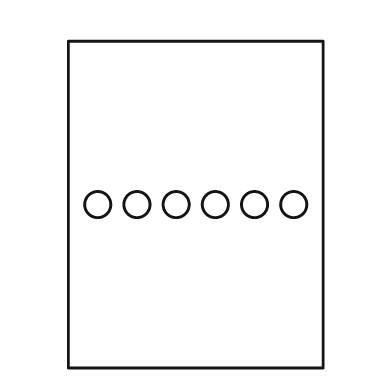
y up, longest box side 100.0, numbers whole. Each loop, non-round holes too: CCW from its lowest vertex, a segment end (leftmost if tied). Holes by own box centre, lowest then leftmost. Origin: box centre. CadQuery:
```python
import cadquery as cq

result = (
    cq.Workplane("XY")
    .moveTo(-39.0, -50.0)
    .lineTo(39.0, -50.0)
    .lineTo(39.0, 50.0)
    .lineTo(-39.0, 50.0)
    .close()
    .moveTo(-30.0, 0.0)
    .circle(4.0)
    .moveTo(-18.0, 0.0)
    .circle(4.0)
    .moveTo(-6.0, 0.0)
    .circle(4.0)
    .moveTo(6.0, 0.0)
    .circle(4.0)
    .moveTo(18.0, 0.0)
    .circle(4.0)
    .moveTo(30.0, 0.0)
    .circle(4.0)
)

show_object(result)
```